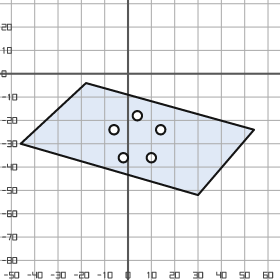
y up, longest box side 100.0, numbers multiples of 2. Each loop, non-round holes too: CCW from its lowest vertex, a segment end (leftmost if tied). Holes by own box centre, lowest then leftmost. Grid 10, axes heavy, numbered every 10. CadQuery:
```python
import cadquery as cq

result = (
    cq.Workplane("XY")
    .moveTo(30.0, -52.0)
    .lineTo(54.0, -24.0)
    .lineTo(-18.0, -4.0)
    .lineTo(-46.0, -30.0)
    .close()
    .moveTo(-2.0, -36.0)
    .circle(2.0)
    .moveTo(10.0, -36.0)
    .circle(2.0)
    .moveTo(-6.0, -24.0)
    .circle(2.0)
    .moveTo(14.0, -24.0)
    .circle(2.0)
    .moveTo(4.0, -18.0)
    .circle(2.0)
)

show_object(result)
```